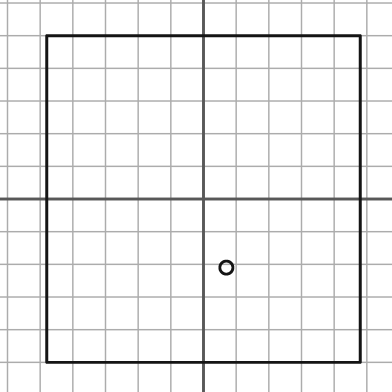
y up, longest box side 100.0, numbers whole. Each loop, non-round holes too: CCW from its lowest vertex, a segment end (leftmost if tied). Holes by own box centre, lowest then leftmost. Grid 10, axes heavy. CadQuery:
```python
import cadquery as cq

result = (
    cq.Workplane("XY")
    .moveTo(-48.0, -50.0)
    .lineTo(48.0, -50.0)
    .lineTo(48.0, 50.0)
    .lineTo(-48.0, 50.0)
    .close()
    .moveTo(7.0, -21.0)
    .circle(2.0)
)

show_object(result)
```